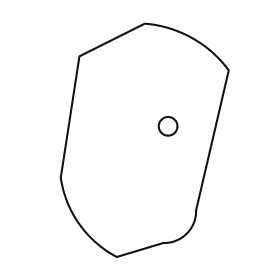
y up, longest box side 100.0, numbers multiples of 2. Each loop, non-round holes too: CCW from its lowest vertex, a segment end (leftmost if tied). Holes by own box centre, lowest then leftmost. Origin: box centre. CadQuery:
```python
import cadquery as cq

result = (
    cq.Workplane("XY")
    .moveTo(-12.0, -50.0)
    .lineTo(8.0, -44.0)
    .threePointArc((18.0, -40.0), (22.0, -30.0))
    .lineTo(36.0, 30.0)
    .threePointArc((20.0, 44.0), (0.0, 50.0))
    .lineTo(-28.0, 36.0)
    .lineTo(-36.0, -16.0)
    .threePointArc((-28.0, -36.0), (-12.0, -50.0))
    .close()
    .moveTo(10.0, 6.0)
    .circle(4.0)
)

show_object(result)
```